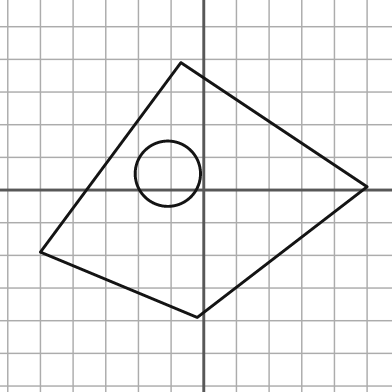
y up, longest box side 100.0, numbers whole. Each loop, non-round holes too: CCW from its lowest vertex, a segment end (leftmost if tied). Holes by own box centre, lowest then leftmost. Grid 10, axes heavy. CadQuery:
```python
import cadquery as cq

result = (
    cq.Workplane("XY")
    .moveTo(-2.0, -39.0)
    .lineTo(50.0, 1.0)
    .lineTo(-7.0, 39.0)
    .lineTo(-50.0, -19.0)
    .close()
    .moveTo(-11.0, 5.0)
    .circle(10.0)
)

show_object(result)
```